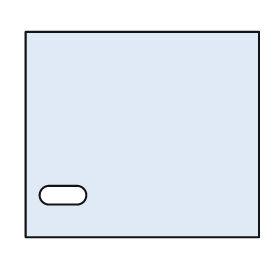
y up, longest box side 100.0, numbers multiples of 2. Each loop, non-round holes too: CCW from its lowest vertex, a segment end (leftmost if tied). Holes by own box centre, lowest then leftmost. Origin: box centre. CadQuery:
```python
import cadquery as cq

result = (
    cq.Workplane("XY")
    .moveTo(-50.0, -44.0)
    .lineTo(50.0, -44.0)
    .lineTo(50.0, 44.0)
    .lineTo(-50.0, 44.0)
    .close()
    .moveTo(-40.0, -30.0)
    .lineTo(-28.0, -30.0)
    .threePointArc((-24.0, -26.0), (-28.0, -22.0))
    .lineTo(-40.0, -22.0)
    .threePointArc((-44.0, -26.0), (-40.0, -30.0))
    .close()
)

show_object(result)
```